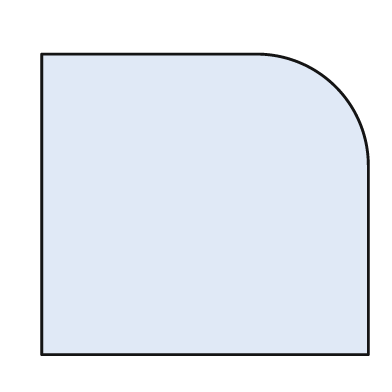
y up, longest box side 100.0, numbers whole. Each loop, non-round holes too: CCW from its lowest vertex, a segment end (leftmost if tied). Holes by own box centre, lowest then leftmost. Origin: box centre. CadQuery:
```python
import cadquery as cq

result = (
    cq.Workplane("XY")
    .moveTo(-50.0, -46.0)
    .lineTo(50.0, -46.0)
    .lineTo(50.0, 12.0)
    .threePointArc((40.0, 36.0), (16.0, 46.0))
    .lineTo(-50.0, 46.0)
    .close()
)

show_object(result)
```